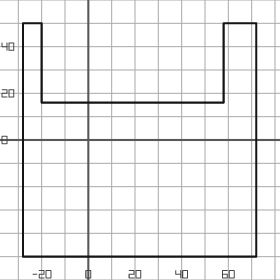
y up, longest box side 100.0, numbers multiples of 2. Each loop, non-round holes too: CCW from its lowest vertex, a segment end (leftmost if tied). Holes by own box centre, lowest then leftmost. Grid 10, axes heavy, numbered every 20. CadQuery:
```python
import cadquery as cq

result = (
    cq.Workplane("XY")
    .moveTo(-28.0, -50.0)
    .lineTo(72.0, -50.0)
    .lineTo(72.0, 50.0)
    .lineTo(58.0, 50.0)
    .lineTo(58.0, 16.0)
    .lineTo(-20.0, 16.0)
    .lineTo(-20.0, 50.0)
    .lineTo(-28.0, 50.0)
    .close()
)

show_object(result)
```